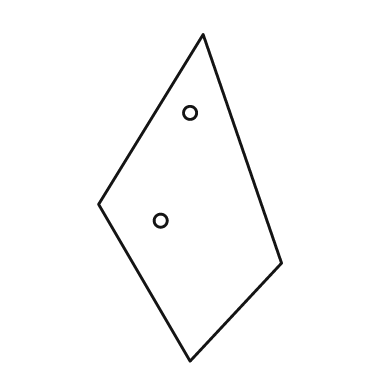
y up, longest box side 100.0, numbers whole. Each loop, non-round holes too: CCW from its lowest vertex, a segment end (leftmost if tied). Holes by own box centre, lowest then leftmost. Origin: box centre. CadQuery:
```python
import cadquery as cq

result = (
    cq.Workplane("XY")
    .moveTo(0.0, -50.0)
    .lineTo(28.0, -20.0)
    .lineTo(4.0, 50.0)
    .lineTo(-28.0, -2.0)
    .close()
    .moveTo(-9.0, -7.0)
    .circle(2.0)
    .moveTo(0.0, 26.0)
    .circle(2.0)
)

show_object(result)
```